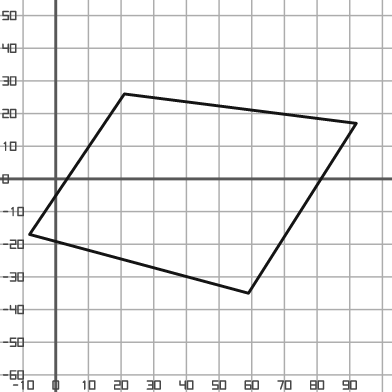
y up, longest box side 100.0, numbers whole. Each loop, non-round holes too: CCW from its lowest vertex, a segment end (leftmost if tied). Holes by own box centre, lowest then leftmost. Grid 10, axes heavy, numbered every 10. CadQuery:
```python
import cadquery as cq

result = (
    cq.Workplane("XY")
    .moveTo(59.0, -35.0)
    .lineTo(92.0, 17.0)
    .lineTo(21.0, 26.0)
    .lineTo(-8.0, -17.0)
    .close()
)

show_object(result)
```